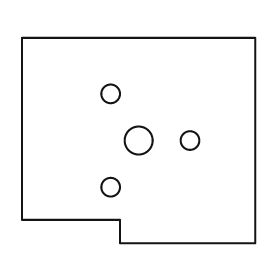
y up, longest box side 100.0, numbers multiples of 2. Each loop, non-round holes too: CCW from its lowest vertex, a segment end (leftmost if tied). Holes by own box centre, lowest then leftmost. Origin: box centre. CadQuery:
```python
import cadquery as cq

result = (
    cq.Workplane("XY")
    .moveTo(-8.0, -44.0)
    .lineTo(50.0, -44.0)
    .lineTo(50.0, 44.0)
    .lineTo(-50.0, 44.0)
    .lineTo(-50.0, -34.0)
    .lineTo(-8.0, -34.0)
    .close()
    .moveTo(-12.0, -20.0)
    .circle(4.0)
    .moveTo(0.0, 0.0)
    .circle(6.0)
    .moveTo(22.0, 0.0)
    .circle(4.0)
    .moveTo(-12.0, 20.0)
    .circle(4.0)
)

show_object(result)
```